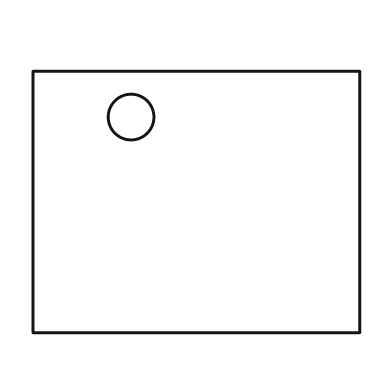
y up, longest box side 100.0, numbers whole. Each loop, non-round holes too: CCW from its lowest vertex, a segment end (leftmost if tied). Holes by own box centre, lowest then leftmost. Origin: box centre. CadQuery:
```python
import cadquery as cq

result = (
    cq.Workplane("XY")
    .moveTo(-50.0, -40.0)
    .lineTo(50.0, -40.0)
    .lineTo(50.0, 40.0)
    .lineTo(-50.0, 40.0)
    .close()
    .moveTo(-20.0, 26.0)
    .circle(7.0)
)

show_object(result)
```